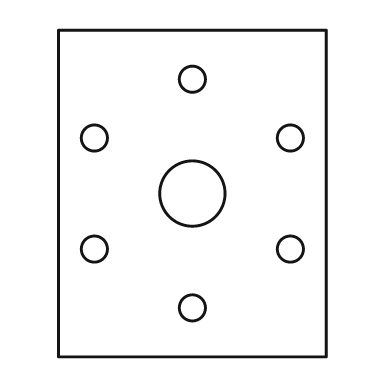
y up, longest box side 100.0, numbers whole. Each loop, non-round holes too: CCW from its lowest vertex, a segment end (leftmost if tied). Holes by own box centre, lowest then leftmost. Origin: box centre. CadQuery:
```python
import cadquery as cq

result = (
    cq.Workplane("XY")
    .moveTo(-41.0, -50.0)
    .lineTo(41.0, -50.0)
    .lineTo(41.0, 50.0)
    .lineTo(-41.0, 50.0)
    .close()
    .moveTo(0.0, -35.0)
    .circle(4.0)
    .moveTo(-30.0, -17.0)
    .circle(4.0)
    .moveTo(30.0, -17.0)
    .circle(4.0)
    .moveTo(0.0, 0.0)
    .circle(10.0)
    .moveTo(-30.0, 17.0)
    .circle(4.0)
    .moveTo(30.0, 17.0)
    .circle(4.0)
    .moveTo(0.0, 35.0)
    .circle(4.0)
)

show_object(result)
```